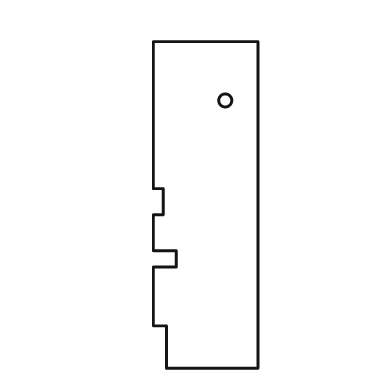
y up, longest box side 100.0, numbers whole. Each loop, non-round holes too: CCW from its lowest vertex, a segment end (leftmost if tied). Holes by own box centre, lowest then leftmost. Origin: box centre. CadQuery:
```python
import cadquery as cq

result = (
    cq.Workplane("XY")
    .moveTo(-12.0, -50.0)
    .lineTo(16.0, -50.0)
    .lineTo(16.0, 50.0)
    .lineTo(-16.0, 50.0)
    .lineTo(-16.0, 5.0)
    .lineTo(-13.0, 5.0)
    .lineTo(-13.0, -3.0)
    .lineTo(-16.0, -3.0)
    .lineTo(-16.0, -14.0)
    .lineTo(-9.0, -14.0)
    .lineTo(-9.0, -19.0)
    .lineTo(-16.0, -19.0)
    .lineTo(-16.0, -37.0)
    .lineTo(-12.0, -37.0)
    .close()
    .moveTo(6.0, 32.0)
    .circle(2.0)
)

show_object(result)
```